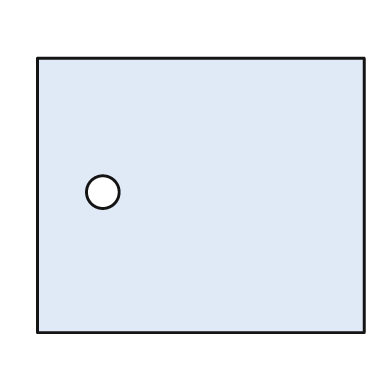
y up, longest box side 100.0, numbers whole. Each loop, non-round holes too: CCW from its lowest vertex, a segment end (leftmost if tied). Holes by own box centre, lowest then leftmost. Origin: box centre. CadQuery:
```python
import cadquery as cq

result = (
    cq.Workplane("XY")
    .moveTo(-50.0, -42.0)
    .lineTo(50.0, -42.0)
    .lineTo(50.0, 42.0)
    .lineTo(-50.0, 42.0)
    .close()
    .moveTo(-30.0, 1.0)
    .circle(5.0)
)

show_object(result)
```